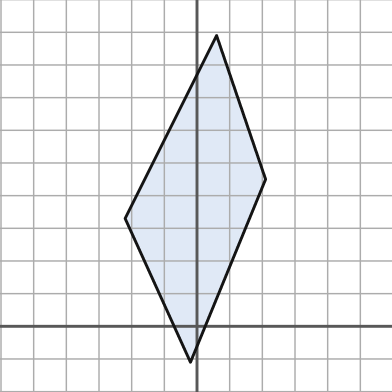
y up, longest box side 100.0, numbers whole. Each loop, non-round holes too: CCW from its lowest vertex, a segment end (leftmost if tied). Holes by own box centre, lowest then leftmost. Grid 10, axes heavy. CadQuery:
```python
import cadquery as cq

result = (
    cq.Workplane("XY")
    .moveTo(-2.0, -11.0)
    .lineTo(21.0, 45.0)
    .lineTo(6.0, 89.0)
    .lineTo(-22.0, 33.0)
    .close()
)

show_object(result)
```